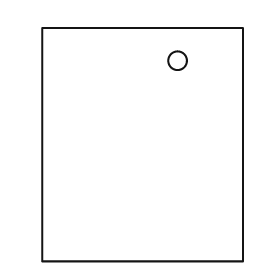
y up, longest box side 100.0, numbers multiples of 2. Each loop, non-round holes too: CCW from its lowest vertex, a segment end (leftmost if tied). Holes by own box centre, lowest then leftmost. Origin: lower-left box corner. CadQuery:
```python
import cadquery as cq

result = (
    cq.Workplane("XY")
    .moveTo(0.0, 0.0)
    .lineTo(86.0, 0.0)
    .lineTo(86.0, 100.0)
    .lineTo(0.0, 100.0)
    .close()
    .moveTo(58.0, 86.0)
    .circle(4.0)
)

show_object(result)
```